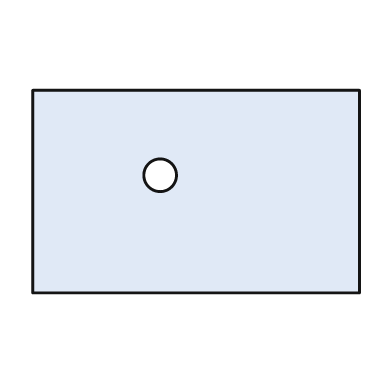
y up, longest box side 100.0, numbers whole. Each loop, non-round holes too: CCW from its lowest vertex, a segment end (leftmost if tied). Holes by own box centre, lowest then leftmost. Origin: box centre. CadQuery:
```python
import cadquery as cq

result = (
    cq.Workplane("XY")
    .moveTo(-50.0, -31.0)
    .lineTo(50.0, -31.0)
    .lineTo(50.0, 31.0)
    .lineTo(-50.0, 31.0)
    .close()
    .moveTo(-11.0, 5.0)
    .circle(5.0)
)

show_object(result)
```